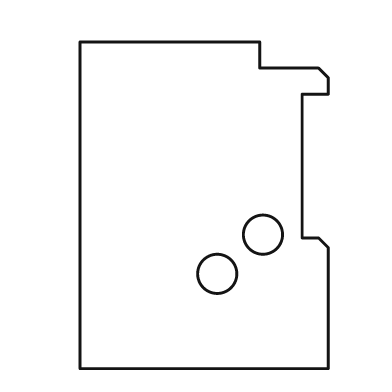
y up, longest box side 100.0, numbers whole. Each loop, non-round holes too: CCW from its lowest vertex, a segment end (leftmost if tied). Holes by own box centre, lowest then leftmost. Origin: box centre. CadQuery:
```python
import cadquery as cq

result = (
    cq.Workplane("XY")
    .moveTo(-38.0, -50.0)
    .lineTo(38.0, -50.0)
    .lineTo(38.0, -13.0)
    .lineTo(35.0, -10.0)
    .lineTo(30.0, -10.0)
    .lineTo(30.0, 34.0)
    .lineTo(38.0, 34.0)
    .lineTo(38.0, 39.0)
    .lineTo(35.0, 42.0)
    .lineTo(17.0, 42.0)
    .lineTo(17.0, 50.0)
    .lineTo(-38.0, 50.0)
    .close()
    .moveTo(4.0, -21.0)
    .circle(6.0)
    .moveTo(18.0, -9.0)
    .circle(6.0)
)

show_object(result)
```